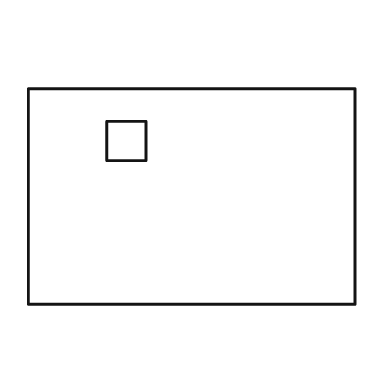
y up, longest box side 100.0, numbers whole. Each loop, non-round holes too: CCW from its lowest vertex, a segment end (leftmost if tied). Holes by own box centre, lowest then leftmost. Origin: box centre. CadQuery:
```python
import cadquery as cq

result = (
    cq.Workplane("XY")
    .moveTo(-50.0, -33.0)
    .lineTo(50.0, -33.0)
    .lineTo(50.0, 33.0)
    .lineTo(-50.0, 33.0)
    .close()
    .moveTo(-26.0, 11.0)
    .lineTo(-14.0, 11.0)
    .lineTo(-14.0, 23.0)
    .lineTo(-26.0, 23.0)
    .close()
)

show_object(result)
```